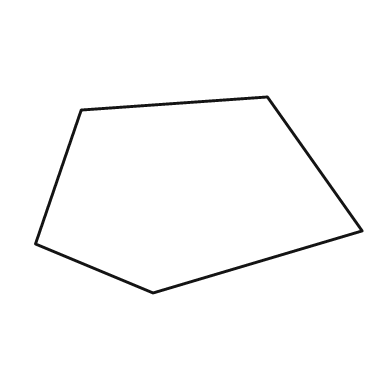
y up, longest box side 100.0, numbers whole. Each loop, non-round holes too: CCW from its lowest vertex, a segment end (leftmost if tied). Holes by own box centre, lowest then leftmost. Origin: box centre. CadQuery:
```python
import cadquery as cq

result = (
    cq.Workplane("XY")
    .moveTo(-14.0, -30.0)
    .lineTo(50.0, -11.0)
    .lineTo(21.0, 30.0)
    .lineTo(-36.0, 26.0)
    .lineTo(-50.0, -15.0)
    .close()
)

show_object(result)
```